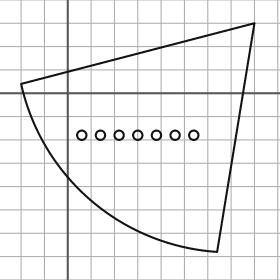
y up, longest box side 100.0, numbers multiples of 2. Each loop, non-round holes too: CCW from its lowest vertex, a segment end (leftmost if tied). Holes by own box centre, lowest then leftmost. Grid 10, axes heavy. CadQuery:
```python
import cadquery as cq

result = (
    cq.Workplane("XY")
    .moveTo(64.0, -68.0)
    .lineTo(80.0, 30.0)
    .lineTo(-20.0, 4.0)
    .threePointArc((10.0, -46.0), (64.0, -68.0))
    .close()
    .moveTo(6.0, -18.0)
    .circle(2.0)
    .moveTo(14.0, -18.0)
    .circle(2.0)
    .moveTo(22.0, -18.0)
    .circle(2.0)
    .moveTo(30.0, -18.0)
    .circle(2.0)
    .moveTo(38.0, -18.0)
    .circle(2.0)
    .moveTo(46.0, -18.0)
    .circle(2.0)
    .moveTo(54.0, -18.0)
    .circle(2.0)
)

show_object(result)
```